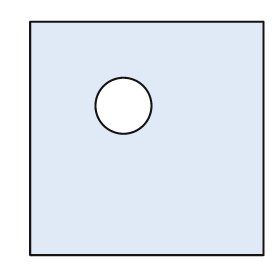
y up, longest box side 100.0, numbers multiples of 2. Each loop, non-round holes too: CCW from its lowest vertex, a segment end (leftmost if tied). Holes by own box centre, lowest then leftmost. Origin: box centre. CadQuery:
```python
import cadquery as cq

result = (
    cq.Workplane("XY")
    .moveTo(-50.0, -50.0)
    .lineTo(50.0, -50.0)
    .lineTo(50.0, 50.0)
    .lineTo(-50.0, 50.0)
    .close()
    .moveTo(-10.0, 14.0)
    .circle(12.0)
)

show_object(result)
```